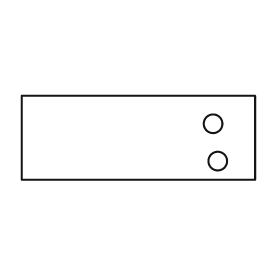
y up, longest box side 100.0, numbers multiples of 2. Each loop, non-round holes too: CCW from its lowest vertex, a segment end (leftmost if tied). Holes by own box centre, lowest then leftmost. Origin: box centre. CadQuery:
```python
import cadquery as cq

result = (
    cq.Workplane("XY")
    .moveTo(-50.0, -18.0)
    .lineTo(50.0, -18.0)
    .lineTo(50.0, 18.0)
    .lineTo(-50.0, 18.0)
    .close()
    .moveTo(34.0, -10.0)
    .circle(4.0)
    .moveTo(32.0, 6.0)
    .circle(4.0)
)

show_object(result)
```